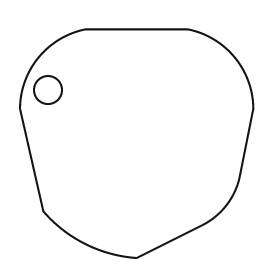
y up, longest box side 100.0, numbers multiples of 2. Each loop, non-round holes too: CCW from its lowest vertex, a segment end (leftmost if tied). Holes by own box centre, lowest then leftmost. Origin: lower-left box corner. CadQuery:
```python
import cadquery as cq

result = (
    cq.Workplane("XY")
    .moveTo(50.0, 0.0)
    .lineTo(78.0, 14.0)
    .threePointArc((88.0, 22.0), (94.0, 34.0))
    .lineTo(100.0, 64.0)
    .threePointArc((92.0, 86.0), (72.0, 98.0))
    .lineTo(28.0, 98.0)
    .threePointArc((8.0, 86.0), (0.0, 64.0))
    .lineTo(10.0, 20.0)
    .threePointArc((28.0, 6.0), (50.0, 0.0))
    .close()
    .moveTo(12.0, 72.0)
    .circle(6.0)
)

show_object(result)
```